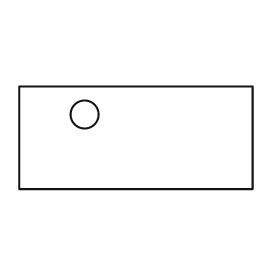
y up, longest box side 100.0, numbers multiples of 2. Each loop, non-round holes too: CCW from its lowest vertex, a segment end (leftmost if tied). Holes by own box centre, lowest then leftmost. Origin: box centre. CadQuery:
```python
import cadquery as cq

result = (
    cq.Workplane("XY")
    .moveTo(-50.0, -22.0)
    .lineTo(50.0, -22.0)
    .lineTo(50.0, 22.0)
    .lineTo(-50.0, 22.0)
    .close()
    .moveTo(-22.0, 10.0)
    .circle(6.0)
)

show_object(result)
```